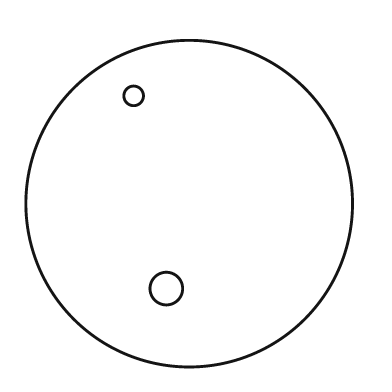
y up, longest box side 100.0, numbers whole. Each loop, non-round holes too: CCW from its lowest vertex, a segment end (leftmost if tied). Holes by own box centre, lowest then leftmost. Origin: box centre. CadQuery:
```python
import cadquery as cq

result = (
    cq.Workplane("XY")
    .moveTo(0.0, 0.0)
    .circle(50.0)
    .moveTo(-7.0, -26.0)
    .circle(5.0)
    .moveTo(-17.0, 33.0)
    .circle(3.0)
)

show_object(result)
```